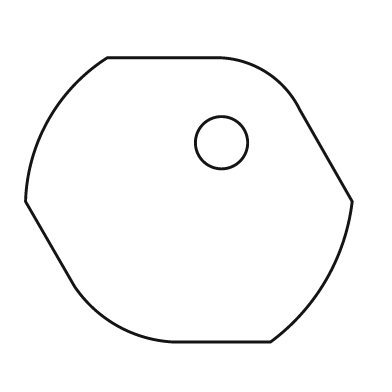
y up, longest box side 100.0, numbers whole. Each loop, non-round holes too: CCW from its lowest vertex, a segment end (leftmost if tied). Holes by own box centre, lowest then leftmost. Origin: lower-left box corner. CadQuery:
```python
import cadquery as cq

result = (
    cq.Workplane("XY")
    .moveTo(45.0, 0.0)
    .lineTo(75.0, 0.0)
    .threePointArc((92.0, 19.0), (100.0, 43.0))
    .lineTo(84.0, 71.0)
    .threePointArc((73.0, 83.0), (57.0, 87.0))
    .lineTo(25.0, 87.0)
    .threePointArc((7.0, 68.0), (0.0, 43.0))
    .lineTo(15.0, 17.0)
    .threePointArc((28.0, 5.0), (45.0, 0.0))
    .close()
    .moveTo(60.0, 61.0)
    .circle(8.0)
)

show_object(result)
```